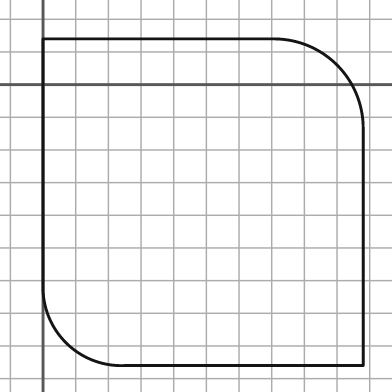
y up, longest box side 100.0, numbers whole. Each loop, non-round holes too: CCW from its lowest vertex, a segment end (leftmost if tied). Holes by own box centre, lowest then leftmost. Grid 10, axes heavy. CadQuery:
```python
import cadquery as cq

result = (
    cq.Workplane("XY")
    .moveTo(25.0, -86.0)
    .lineTo(98.0, -86.0)
    .lineTo(98.0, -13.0)
    .threePointArc((90.0, 6.0), (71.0, 14.0))
    .lineTo(0.0, 14.0)
    .lineTo(0.0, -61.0)
    .threePointArc((7.0, -79.0), (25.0, -86.0))
    .close()
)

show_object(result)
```